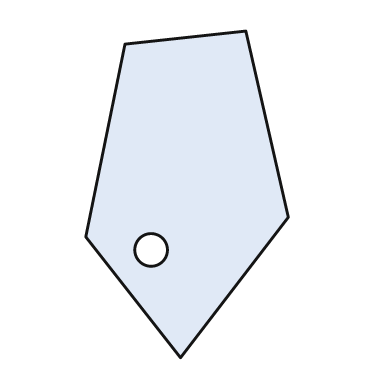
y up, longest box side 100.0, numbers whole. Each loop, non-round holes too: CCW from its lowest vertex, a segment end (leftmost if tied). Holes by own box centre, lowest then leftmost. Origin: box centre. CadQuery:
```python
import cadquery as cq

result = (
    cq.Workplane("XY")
    .moveTo(-2.0, -50.0)
    .lineTo(31.0, -7.0)
    .lineTo(18.0, 50.0)
    .lineTo(-19.0, 46.0)
    .lineTo(-31.0, -13.0)
    .close()
    .moveTo(-11.0, -17.0)
    .circle(5.0)
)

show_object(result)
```